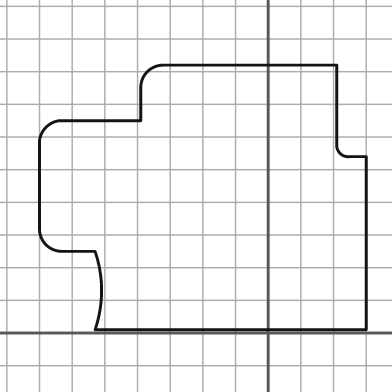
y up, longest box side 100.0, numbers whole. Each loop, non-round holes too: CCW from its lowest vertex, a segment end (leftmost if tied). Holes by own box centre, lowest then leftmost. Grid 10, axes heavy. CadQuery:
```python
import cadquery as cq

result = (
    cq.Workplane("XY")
    .moveTo(-53.0, 1.0)
    .lineTo(30.0, 1.0)
    .lineTo(30.0, 54.0)
    .lineTo(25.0, 54.0)
    .threePointArc((22.0, 55.0), (21.0, 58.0))
    .lineTo(21.0, 82.0)
    .lineTo(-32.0, 82.0)
    .threePointArc((-37.0, 80.0), (-39.0, 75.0))
    .lineTo(-39.0, 65.0)
    .lineTo(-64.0, 65.0)
    .threePointArc((-68.0, 63.0), (-70.0, 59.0))
    .lineTo(-70.0, 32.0)
    .threePointArc((-68.0, 27.0), (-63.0, 25.0))
    .lineTo(-53.0, 25.0)
    .threePointArc((-51.0, 13.0), (-53.0, 1.0))
    .close()
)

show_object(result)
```